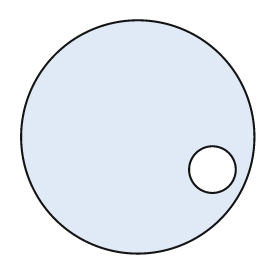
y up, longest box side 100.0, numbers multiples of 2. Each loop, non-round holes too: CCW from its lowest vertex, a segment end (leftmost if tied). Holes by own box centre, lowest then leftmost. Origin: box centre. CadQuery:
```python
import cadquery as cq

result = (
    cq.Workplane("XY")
    .moveTo(0.0, 0.0)
    .circle(50.0)
    .moveTo(32.0, -14.0)
    .circle(10.0)
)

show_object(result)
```